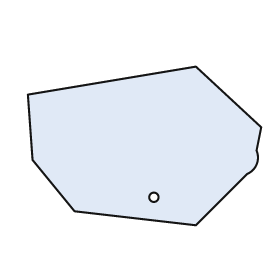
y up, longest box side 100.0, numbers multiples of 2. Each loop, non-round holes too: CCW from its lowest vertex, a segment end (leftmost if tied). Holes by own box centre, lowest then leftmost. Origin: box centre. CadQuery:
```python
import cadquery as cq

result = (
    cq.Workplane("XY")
    .moveTo(22.0, -34.0)
    .lineTo(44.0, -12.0)
    .threePointArc((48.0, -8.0), (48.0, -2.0))
    .lineTo(50.0, 8.0)
    .lineTo(22.0, 34.0)
    .lineTo(-50.0, 22.0)
    .lineTo(-48.0, -6.0)
    .lineTo(-30.0, -28.0)
    .close()
    .moveTo(4.0, -22.0)
    .circle(2.0)
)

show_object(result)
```